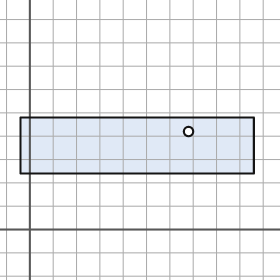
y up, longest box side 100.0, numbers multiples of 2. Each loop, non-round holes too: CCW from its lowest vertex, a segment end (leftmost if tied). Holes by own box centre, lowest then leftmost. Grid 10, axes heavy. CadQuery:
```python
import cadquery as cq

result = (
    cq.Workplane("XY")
    .moveTo(-4.0, 24.0)
    .lineTo(96.0, 24.0)
    .lineTo(96.0, 48.0)
    .lineTo(-4.0, 48.0)
    .close()
    .moveTo(68.0, 42.0)
    .circle(2.0)
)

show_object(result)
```